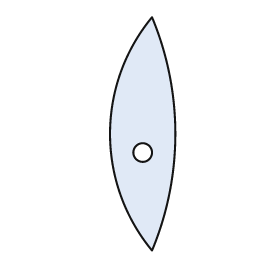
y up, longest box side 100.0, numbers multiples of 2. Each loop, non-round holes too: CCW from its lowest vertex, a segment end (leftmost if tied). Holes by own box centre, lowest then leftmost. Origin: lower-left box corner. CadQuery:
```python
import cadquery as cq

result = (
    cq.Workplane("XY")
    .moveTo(18.0, 0.0)
    .threePointArc((28.0, 50.0), (18.0, 100.0))
    .threePointArc((0.0, 50.0), (18.0, 0.0))
    .close()
    .moveTo(14.0, 42.0)
    .circle(4.0)
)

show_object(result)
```